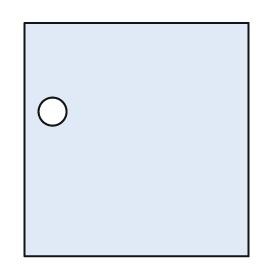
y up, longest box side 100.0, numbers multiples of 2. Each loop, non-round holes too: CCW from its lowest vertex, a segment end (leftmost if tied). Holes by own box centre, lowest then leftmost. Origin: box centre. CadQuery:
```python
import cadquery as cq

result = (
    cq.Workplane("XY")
    .moveTo(-48.0, -50.0)
    .lineTo(48.0, -50.0)
    .lineTo(48.0, 50.0)
    .lineTo(-48.0, 50.0)
    .close()
    .moveTo(-36.0, 12.0)
    .circle(6.0)
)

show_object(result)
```